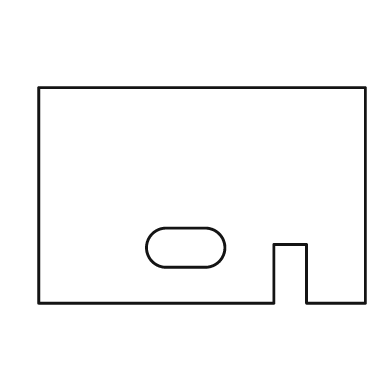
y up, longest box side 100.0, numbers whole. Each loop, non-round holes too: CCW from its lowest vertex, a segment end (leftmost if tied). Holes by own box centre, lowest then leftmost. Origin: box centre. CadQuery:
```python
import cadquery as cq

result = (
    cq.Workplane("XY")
    .moveTo(-50.0, -33.0)
    .lineTo(22.0, -33.0)
    .lineTo(22.0, -15.0)
    .lineTo(32.0, -15.0)
    .lineTo(32.0, -33.0)
    .lineTo(50.0, -33.0)
    .lineTo(50.0, 33.0)
    .lineTo(-50.0, 33.0)
    .close()
    .moveTo(-11.0, -22.0)
    .lineTo(1.0, -22.0)
    .threePointArc((7.0, -16.0), (1.0, -10.0))
    .lineTo(-11.0, -10.0)
    .threePointArc((-17.0, -16.0), (-11.0, -22.0))
    .close()
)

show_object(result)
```